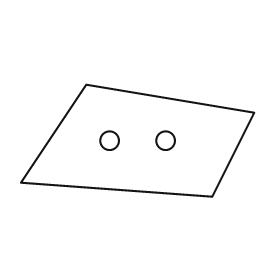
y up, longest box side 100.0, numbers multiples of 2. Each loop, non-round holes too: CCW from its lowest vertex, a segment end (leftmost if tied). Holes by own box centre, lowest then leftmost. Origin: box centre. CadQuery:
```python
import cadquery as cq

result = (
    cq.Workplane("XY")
    .moveTo(32.0, -24.0)
    .lineTo(50.0, 12.0)
    .lineTo(-22.0, 24.0)
    .lineTo(-50.0, -18.0)
    .close()
    .moveTo(-12.0, 0.0)
    .circle(4.0)
    .moveTo(12.0, 0.0)
    .circle(4.0)
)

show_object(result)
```